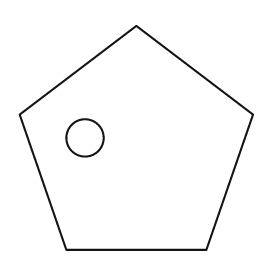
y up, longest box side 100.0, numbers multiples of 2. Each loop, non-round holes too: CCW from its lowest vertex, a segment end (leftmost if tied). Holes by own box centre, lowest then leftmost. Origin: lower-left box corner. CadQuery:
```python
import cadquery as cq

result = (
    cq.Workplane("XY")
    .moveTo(20.0, 0.0)
    .lineTo(80.0, 0.0)
    .lineTo(100.0, 58.0)
    .lineTo(50.0, 96.0)
    .lineTo(0.0, 58.0)
    .close()
    .moveTo(28.0, 48.0)
    .circle(8.0)
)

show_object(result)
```